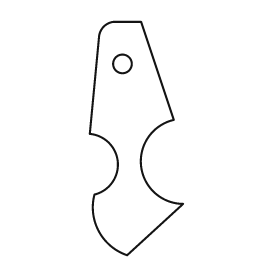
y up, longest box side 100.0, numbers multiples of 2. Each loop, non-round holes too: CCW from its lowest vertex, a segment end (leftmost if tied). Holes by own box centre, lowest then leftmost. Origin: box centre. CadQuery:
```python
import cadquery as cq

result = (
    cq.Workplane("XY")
    .moveTo(-4.0, -50.0)
    .lineTo(20.0, -28.0)
    .threePointArc((2.0, -12.0), (16.0, 8.0))
    .lineTo(2.0, 50.0)
    .lineTo(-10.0, 50.0)
    .threePointArc((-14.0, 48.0), (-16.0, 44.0))
    .lineTo(-20.0, 2.0)
    .threePointArc((-8.0, -10.0), (-18.0, -24.0))
    .threePointArc((-16.0, -40.0), (-4.0, -50.0))
    .close()
    .moveTo(-6.0, 32.0)
    .circle(4.0)
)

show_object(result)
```